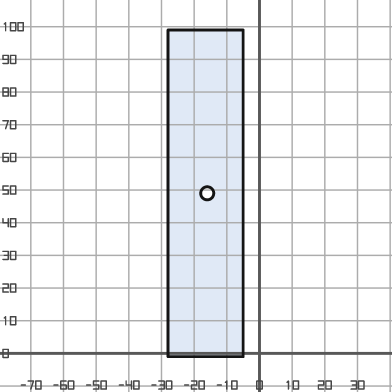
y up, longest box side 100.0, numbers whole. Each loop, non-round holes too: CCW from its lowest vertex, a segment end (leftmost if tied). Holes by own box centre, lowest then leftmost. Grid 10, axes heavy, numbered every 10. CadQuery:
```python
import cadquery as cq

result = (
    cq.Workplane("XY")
    .moveTo(-28.0, -1.0)
    .lineTo(-5.0, -1.0)
    .lineTo(-5.0, 99.0)
    .lineTo(-28.0, 99.0)
    .close()
    .moveTo(-16.0, 49.0)
    .circle(2.0)
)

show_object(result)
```